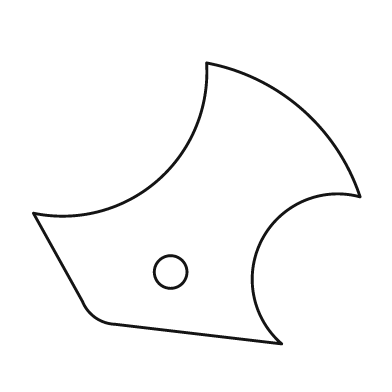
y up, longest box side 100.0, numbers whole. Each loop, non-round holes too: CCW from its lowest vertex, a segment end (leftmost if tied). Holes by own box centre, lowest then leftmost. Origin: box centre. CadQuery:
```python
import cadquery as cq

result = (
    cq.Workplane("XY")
    .moveTo(26.0, -43.0)
    .threePointArc((20.0, -11.0), (50.0, 2.0))
    .threePointArc((32.0, 29.0), (3.0, 43.0))
    .threePointArc((-12.0, 7.0), (-50.0, -3.0))
    .lineTo(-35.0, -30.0)
    .threePointArc((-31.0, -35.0), (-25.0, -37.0))
    .close()
    .moveTo(-8.0, -21.0)
    .circle(5.0)
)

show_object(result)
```